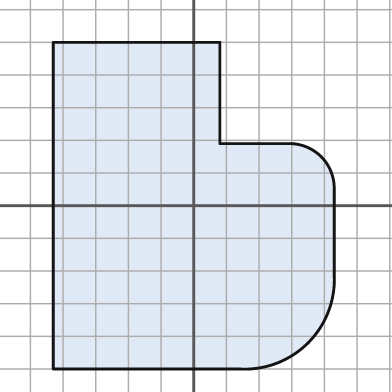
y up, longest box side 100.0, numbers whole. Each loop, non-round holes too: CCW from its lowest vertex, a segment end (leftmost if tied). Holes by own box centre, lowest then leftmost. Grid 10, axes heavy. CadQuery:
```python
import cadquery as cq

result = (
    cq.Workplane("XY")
    .moveTo(-43.0, -50.0)
    .lineTo(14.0, -50.0)
    .threePointArc((35.0, -42.0), (43.0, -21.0))
    .lineTo(43.0, 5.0)
    .threePointArc((39.0, 15.0), (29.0, 19.0))
    .lineTo(8.0, 19.0)
    .lineTo(8.0, 50.0)
    .lineTo(-43.0, 50.0)
    .close()
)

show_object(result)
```